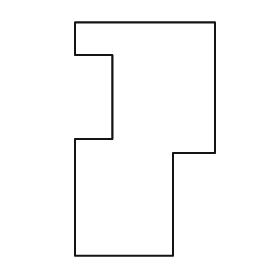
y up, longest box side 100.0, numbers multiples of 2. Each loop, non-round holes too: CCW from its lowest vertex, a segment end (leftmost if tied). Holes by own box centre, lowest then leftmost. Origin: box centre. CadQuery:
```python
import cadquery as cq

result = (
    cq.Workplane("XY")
    .moveTo(-30.0, -50.0)
    .lineTo(12.0, -50.0)
    .lineTo(12.0, -6.0)
    .lineTo(30.0, -6.0)
    .lineTo(30.0, 50.0)
    .lineTo(-30.0, 50.0)
    .lineTo(-30.0, 36.0)
    .lineTo(-14.0, 36.0)
    .lineTo(-14.0, 0.0)
    .lineTo(-30.0, 0.0)
    .close()
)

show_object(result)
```